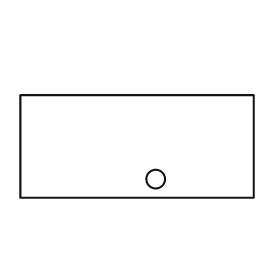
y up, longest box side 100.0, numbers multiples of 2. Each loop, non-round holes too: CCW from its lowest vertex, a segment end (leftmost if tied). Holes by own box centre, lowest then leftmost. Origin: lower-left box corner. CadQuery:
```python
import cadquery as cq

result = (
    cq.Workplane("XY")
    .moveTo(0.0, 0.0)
    .lineTo(100.0, 0.0)
    .lineTo(100.0, 44.0)
    .lineTo(0.0, 44.0)
    .close()
    .moveTo(58.0, 8.0)
    .circle(4.0)
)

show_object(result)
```